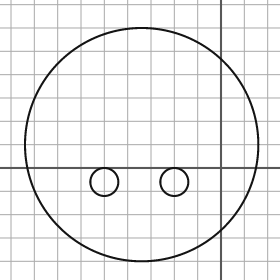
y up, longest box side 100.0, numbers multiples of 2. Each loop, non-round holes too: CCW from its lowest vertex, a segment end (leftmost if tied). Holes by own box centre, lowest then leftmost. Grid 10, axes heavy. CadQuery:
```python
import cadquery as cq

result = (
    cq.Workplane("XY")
    .moveTo(-34.0, 10.0)
    .circle(50.0)
    .moveTo(-50.0, -6.0)
    .circle(6.0)
    .moveTo(-20.0, -6.0)
    .circle(6.0)
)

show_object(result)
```